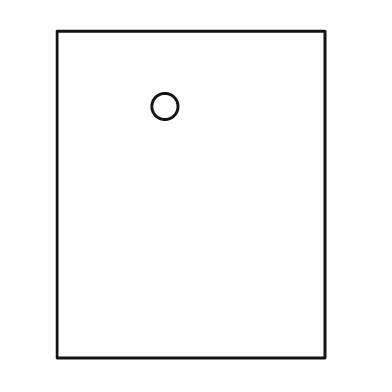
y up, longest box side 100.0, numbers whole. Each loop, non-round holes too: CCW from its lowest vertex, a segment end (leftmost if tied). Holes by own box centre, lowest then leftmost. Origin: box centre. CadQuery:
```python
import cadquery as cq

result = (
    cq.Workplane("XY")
    .moveTo(-41.0, -50.0)
    .lineTo(41.0, -50.0)
    .lineTo(41.0, 50.0)
    .lineTo(-41.0, 50.0)
    .close()
    .moveTo(-8.0, 27.0)
    .circle(4.0)
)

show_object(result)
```